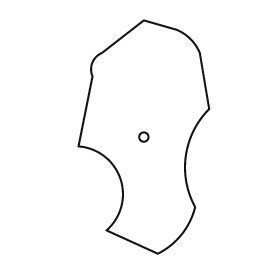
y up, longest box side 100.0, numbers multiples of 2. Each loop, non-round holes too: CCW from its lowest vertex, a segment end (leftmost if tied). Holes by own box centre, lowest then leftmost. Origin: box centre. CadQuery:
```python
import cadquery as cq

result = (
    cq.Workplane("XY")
    .moveTo(6.0, -50.0)
    .threePointArc((16.0, -42.0), (22.0, -30.0))
    .threePointArc((18.0, -8.0), (28.0, 12.0))
    .lineTo(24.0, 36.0)
    .threePointArc((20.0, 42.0), (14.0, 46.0))
    .lineTo(0.0, 50.0)
    .lineTo(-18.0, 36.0)
    .threePointArc((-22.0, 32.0), (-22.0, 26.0))
    .lineTo(-28.0, -4.0)
    .threePointArc((-10.0, -18.0), (-16.0, -40.0))
    .close()
    .moveTo(0.0, 0.0)
    .circle(2.0)
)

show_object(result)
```